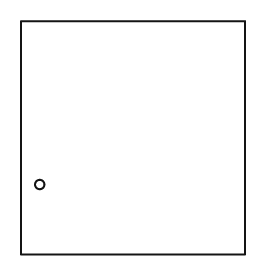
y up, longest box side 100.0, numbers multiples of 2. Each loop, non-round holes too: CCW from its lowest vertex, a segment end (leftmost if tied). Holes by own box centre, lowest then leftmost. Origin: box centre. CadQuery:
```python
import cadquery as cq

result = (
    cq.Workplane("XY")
    .moveTo(-48.0, -50.0)
    .lineTo(48.0, -50.0)
    .lineTo(48.0, 50.0)
    .lineTo(-48.0, 50.0)
    .close()
    .moveTo(-40.0, -20.0)
    .circle(2.0)
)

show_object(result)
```